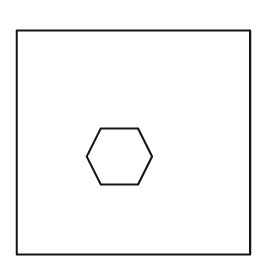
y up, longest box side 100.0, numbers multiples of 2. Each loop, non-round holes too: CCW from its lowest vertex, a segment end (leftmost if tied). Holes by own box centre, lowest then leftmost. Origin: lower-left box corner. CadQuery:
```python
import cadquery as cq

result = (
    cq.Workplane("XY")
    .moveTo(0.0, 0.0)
    .lineTo(100.0, 0.0)
    .lineTo(100.0, 96.0)
    .lineTo(0.0, 96.0)
    .close()
    .moveTo(36.0, 30.0)
    .lineTo(52.0, 30.0)
    .lineTo(58.0, 42.0)
    .lineTo(52.0, 54.0)
    .lineTo(36.0, 54.0)
    .lineTo(30.0, 42.0)
    .close()
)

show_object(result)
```